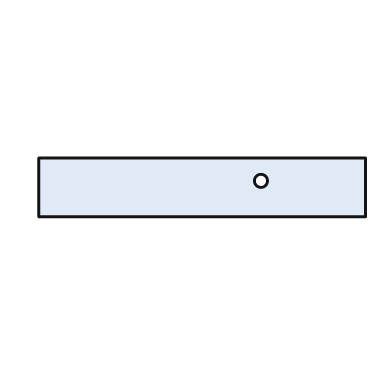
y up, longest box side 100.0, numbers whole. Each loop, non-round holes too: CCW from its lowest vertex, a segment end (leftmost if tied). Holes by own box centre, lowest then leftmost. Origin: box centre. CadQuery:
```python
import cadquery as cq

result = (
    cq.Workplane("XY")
    .moveTo(-50.0, -9.0)
    .lineTo(50.0, -9.0)
    .lineTo(50.0, 9.0)
    .lineTo(-50.0, 9.0)
    .close()
    .moveTo(18.0, 2.0)
    .circle(2.0)
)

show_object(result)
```